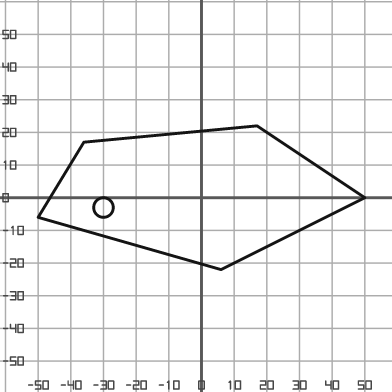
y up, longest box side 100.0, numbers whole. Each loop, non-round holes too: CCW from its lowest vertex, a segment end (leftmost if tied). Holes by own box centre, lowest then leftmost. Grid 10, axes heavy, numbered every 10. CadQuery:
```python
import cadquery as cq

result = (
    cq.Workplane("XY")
    .moveTo(6.0, -22.0)
    .lineTo(50.0, 0.0)
    .lineTo(17.0, 22.0)
    .lineTo(-36.0, 17.0)
    .lineTo(-50.0, -6.0)
    .close()
    .moveTo(-30.0, -3.0)
    .circle(3.0)
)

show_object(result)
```